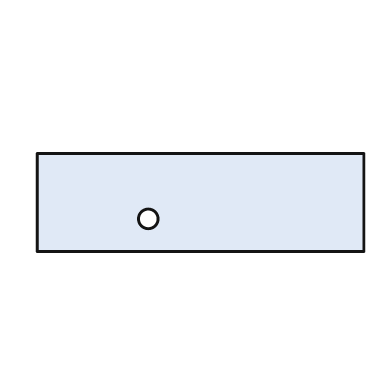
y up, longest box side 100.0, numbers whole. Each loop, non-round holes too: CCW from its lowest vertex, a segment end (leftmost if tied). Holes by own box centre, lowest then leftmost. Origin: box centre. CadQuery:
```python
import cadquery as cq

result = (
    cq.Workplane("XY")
    .moveTo(-50.0, -15.0)
    .lineTo(50.0, -15.0)
    .lineTo(50.0, 15.0)
    .lineTo(-50.0, 15.0)
    .close()
    .moveTo(-16.0, -5.0)
    .circle(3.0)
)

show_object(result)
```